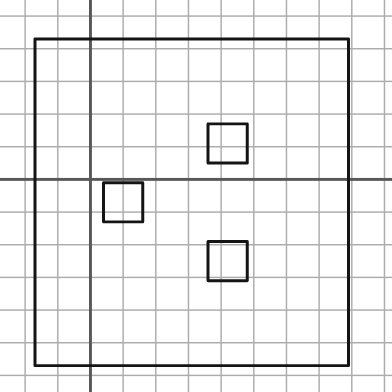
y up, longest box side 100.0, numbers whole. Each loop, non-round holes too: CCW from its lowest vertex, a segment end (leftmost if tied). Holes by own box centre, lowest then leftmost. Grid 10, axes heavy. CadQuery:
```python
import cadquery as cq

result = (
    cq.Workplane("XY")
    .moveTo(-17.0, -57.0)
    .lineTo(79.0, -57.0)
    .lineTo(79.0, 43.0)
    .lineTo(-17.0, 43.0)
    .close()
    .moveTo(36.0, -31.0)
    .lineTo(48.0, -31.0)
    .lineTo(48.0, -19.0)
    .lineTo(36.0, -19.0)
    .close()
    .moveTo(4.0, -13.0)
    .lineTo(16.0, -13.0)
    .lineTo(16.0, -1.0)
    .lineTo(4.0, -1.0)
    .close()
    .moveTo(36.0, 5.0)
    .lineTo(48.0, 5.0)
    .lineTo(48.0, 17.0)
    .lineTo(36.0, 17.0)
    .close()
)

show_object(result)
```